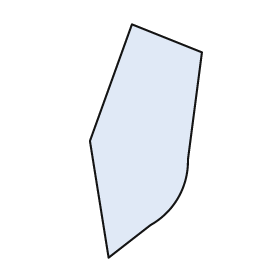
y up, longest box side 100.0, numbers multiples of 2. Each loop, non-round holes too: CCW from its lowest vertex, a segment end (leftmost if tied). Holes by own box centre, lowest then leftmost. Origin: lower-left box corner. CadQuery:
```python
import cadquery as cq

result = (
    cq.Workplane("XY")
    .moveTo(8.0, 0.0)
    .lineTo(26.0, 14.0)
    .threePointArc((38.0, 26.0), (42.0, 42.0))
    .lineTo(48.0, 88.0)
    .lineTo(18.0, 100.0)
    .lineTo(0.0, 50.0)
    .close()
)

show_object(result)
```